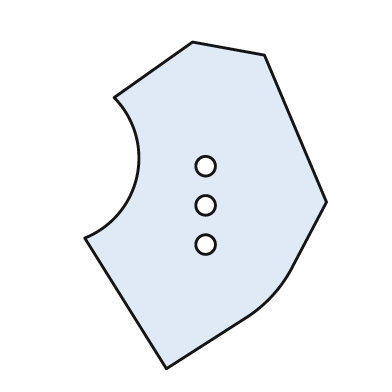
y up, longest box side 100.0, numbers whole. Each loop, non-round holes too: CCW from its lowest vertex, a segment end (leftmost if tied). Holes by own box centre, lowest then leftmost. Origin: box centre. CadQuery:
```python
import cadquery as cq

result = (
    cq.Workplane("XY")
    .moveTo(-12.0, -50.0)
    .lineTo(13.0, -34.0)
    .threePointArc((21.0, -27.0), (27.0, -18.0))
    .lineTo(37.0, 1.0)
    .lineTo(18.0, 46.0)
    .lineTo(-4.0, 50.0)
    .lineTo(-28.0, 33.0)
    .threePointArc((-21.0, 9.0), (-37.0, -10.0))
    .close()
    .moveTo(0.0, -12.0)
    .circle(3.0)
    .moveTo(0.0, 0.0)
    .circle(3.0)
    .moveTo(0.0, 12.0)
    .circle(3.0)
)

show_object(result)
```